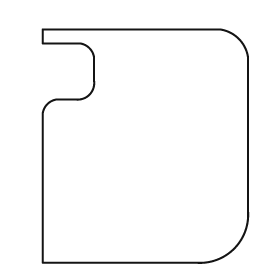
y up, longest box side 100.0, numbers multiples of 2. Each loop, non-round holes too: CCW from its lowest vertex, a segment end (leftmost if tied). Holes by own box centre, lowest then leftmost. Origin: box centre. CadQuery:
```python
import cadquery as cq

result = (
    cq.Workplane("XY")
    .moveTo(-44.0, -50.0)
    .lineTo(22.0, -50.0)
    .threePointArc((38.0, -44.0), (44.0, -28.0))
    .lineTo(44.0, 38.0)
    .threePointArc((40.0, 46.0), (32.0, 50.0))
    .lineTo(-44.0, 50.0)
    .lineTo(-44.0, 44.0)
    .lineTo(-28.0, 44.0)
    .threePointArc((-24.0, 42.0), (-22.0, 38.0))
    .lineTo(-22.0, 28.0)
    .threePointArc((-24.0, 22.0), (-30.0, 20.0))
    .lineTo(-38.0, 20.0)
    .threePointArc((-42.0, 18.0), (-44.0, 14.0))
    .close()
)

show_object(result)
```